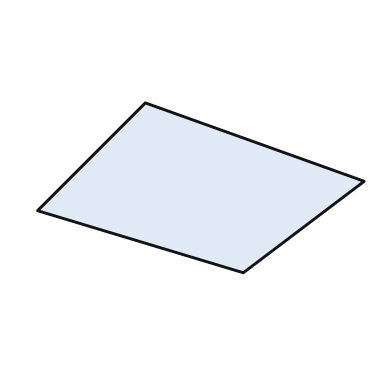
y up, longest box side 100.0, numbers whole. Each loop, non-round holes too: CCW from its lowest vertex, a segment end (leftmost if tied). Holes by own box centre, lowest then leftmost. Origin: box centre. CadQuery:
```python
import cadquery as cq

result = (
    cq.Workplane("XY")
    .moveTo(13.0, -26.0)
    .lineTo(50.0, 2.0)
    .lineTo(-17.0, 26.0)
    .lineTo(-50.0, -7.0)
    .close()
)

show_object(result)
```